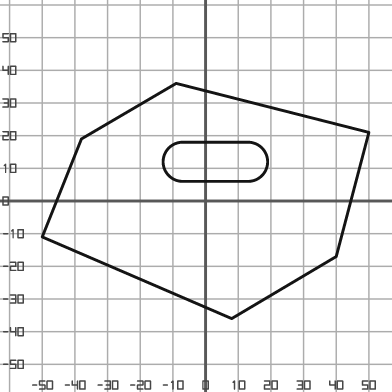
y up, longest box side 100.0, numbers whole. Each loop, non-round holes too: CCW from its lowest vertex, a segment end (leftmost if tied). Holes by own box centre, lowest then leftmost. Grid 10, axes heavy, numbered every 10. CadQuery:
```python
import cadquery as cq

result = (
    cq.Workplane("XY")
    .moveTo(8.0, -36.0)
    .lineTo(40.0, -17.0)
    .lineTo(50.0, 21.0)
    .lineTo(-9.0, 36.0)
    .lineTo(-38.0, 19.0)
    .lineTo(-50.0, -11.0)
    .close()
    .moveTo(-7.0, 6.0)
    .lineTo(13.0, 6.0)
    .threePointArc((19.0, 12.0), (13.0, 18.0))
    .lineTo(-7.0, 18.0)
    .threePointArc((-13.0, 12.0), (-7.0, 6.0))
    .close()
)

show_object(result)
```